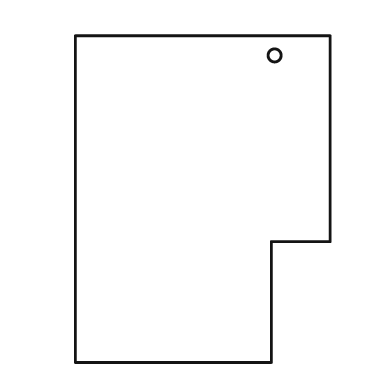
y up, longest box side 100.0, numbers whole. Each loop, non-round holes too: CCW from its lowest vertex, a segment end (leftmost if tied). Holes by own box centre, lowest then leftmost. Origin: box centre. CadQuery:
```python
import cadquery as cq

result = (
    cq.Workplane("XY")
    .moveTo(-39.0, -50.0)
    .lineTo(21.0, -50.0)
    .lineTo(21.0, -13.0)
    .lineTo(39.0, -13.0)
    .lineTo(39.0, 50.0)
    .lineTo(-39.0, 50.0)
    .close()
    .moveTo(22.0, 44.0)
    .circle(2.0)
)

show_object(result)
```